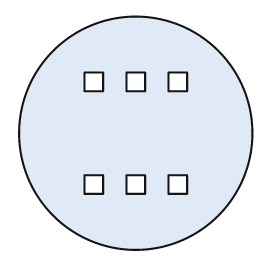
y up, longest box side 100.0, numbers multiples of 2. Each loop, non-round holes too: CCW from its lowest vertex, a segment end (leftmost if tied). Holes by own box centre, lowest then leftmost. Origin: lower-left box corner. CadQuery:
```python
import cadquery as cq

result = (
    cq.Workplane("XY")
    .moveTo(50.0, 50.0)
    .circle(50.0)
    .moveTo(28.0, 24.0)
    .lineTo(36.0, 24.0)
    .lineTo(36.0, 32.0)
    .lineTo(28.0, 32.0)
    .close()
    .moveTo(46.0, 24.0)
    .lineTo(54.0, 24.0)
    .lineTo(54.0, 32.0)
    .lineTo(46.0, 32.0)
    .close()
    .moveTo(64.0, 24.0)
    .lineTo(72.0, 24.0)
    .lineTo(72.0, 32.0)
    .lineTo(64.0, 32.0)
    .close()
    .moveTo(28.0, 68.0)
    .lineTo(36.0, 68.0)
    .lineTo(36.0, 76.0)
    .lineTo(28.0, 76.0)
    .close()
    .moveTo(46.0, 68.0)
    .lineTo(54.0, 68.0)
    .lineTo(54.0, 76.0)
    .lineTo(46.0, 76.0)
    .close()
    .moveTo(64.0, 68.0)
    .lineTo(72.0, 68.0)
    .lineTo(72.0, 76.0)
    .lineTo(64.0, 76.0)
    .close()
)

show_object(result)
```